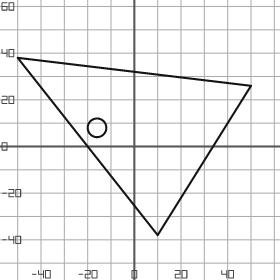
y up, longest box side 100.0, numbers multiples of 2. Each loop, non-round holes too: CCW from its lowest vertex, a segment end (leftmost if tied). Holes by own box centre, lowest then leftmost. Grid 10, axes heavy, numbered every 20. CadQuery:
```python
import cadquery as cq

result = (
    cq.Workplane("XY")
    .moveTo(10.0, -38.0)
    .lineTo(50.0, 26.0)
    .lineTo(-50.0, 38.0)
    .close()
    .moveTo(-16.0, 8.0)
    .circle(4.0)
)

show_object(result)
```